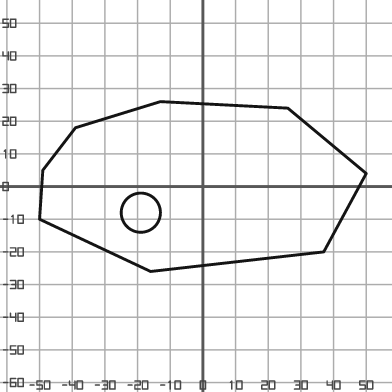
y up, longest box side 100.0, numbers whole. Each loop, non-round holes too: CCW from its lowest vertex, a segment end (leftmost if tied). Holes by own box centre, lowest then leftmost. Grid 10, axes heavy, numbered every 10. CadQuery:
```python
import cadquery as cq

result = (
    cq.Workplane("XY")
    .moveTo(-16.0, -26.0)
    .lineTo(37.0, -20.0)
    .lineTo(50.0, 4.0)
    .lineTo(26.0, 24.0)
    .lineTo(-13.0, 26.0)
    .lineTo(-39.0, 18.0)
    .lineTo(-49.0, 5.0)
    .lineTo(-50.0, -10.0)
    .close()
    .moveTo(-19.0, -8.0)
    .circle(6.0)
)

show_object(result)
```